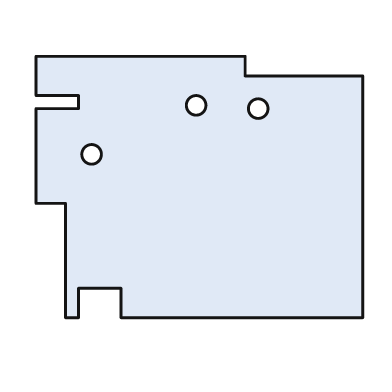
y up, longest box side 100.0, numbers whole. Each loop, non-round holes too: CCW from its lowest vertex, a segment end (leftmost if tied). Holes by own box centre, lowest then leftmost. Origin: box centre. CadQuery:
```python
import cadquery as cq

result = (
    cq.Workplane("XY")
    .moveTo(-41.0, -40.0)
    .lineTo(-37.0, -40.0)
    .lineTo(-37.0, -31.0)
    .lineTo(-24.0, -31.0)
    .lineTo(-24.0, -40.0)
    .lineTo(50.0, -40.0)
    .lineTo(50.0, 34.0)
    .lineTo(14.0, 34.0)
    .lineTo(14.0, 40.0)
    .lineTo(-50.0, 40.0)
    .lineTo(-50.0, 28.0)
    .lineTo(-37.0, 28.0)
    .lineTo(-37.0, 24.0)
    .lineTo(-50.0, 24.0)
    .lineTo(-50.0, -5.0)
    .lineTo(-41.0, -5.0)
    .close()
    .moveTo(-33.0, 10.0)
    .circle(3.0)
    .moveTo(18.0, 24.0)
    .circle(3.0)
    .moveTo(-1.0, 25.0)
    .circle(3.0)
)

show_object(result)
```